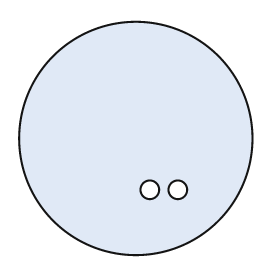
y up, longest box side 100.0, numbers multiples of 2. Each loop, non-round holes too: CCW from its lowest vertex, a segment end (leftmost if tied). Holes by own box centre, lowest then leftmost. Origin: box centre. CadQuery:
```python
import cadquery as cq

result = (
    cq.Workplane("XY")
    .moveTo(0.0, 0.0)
    .circle(50.0)
    .moveTo(6.0, -22.0)
    .circle(4.0)
    .moveTo(18.0, -22.0)
    .circle(4.0)
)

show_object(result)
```